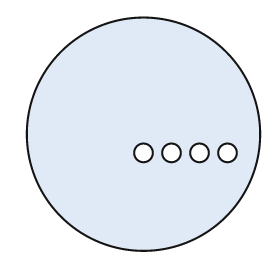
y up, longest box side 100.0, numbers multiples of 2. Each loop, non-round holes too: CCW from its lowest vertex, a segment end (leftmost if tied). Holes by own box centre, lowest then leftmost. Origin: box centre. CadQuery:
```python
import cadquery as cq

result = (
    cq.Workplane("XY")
    .moveTo(0.0, 0.0)
    .circle(50.0)
    .moveTo(0.0, -8.0)
    .circle(4.0)
    .moveTo(12.0, -8.0)
    .circle(4.0)
    .moveTo(24.0, -8.0)
    .circle(4.0)
    .moveTo(36.0, -8.0)
    .circle(4.0)
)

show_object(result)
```